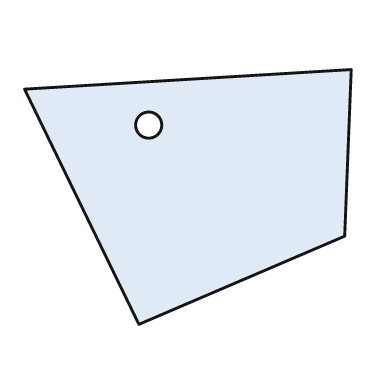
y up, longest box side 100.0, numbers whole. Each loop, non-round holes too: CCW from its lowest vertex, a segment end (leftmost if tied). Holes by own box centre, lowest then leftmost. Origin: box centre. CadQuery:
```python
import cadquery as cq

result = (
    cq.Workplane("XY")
    .moveTo(-15.0, -39.0)
    .lineTo(48.0, -12.0)
    .lineTo(50.0, 39.0)
    .lineTo(-50.0, 33.0)
    .close()
    .moveTo(-12.0, 22.0)
    .circle(4.0)
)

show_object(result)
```